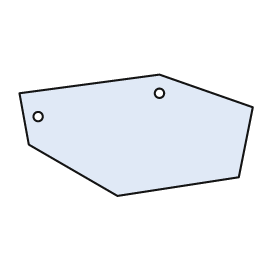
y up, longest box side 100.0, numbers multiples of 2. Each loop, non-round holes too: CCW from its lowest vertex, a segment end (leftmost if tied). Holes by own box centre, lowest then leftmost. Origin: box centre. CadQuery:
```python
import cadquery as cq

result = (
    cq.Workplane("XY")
    .moveTo(-8.0, -26.0)
    .lineTo(44.0, -18.0)
    .lineTo(50.0, 12.0)
    .lineTo(10.0, 26.0)
    .lineTo(-50.0, 18.0)
    .lineTo(-46.0, -4.0)
    .close()
    .moveTo(-42.0, 8.0)
    .circle(2.0)
    .moveTo(10.0, 18.0)
    .circle(2.0)
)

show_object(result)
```